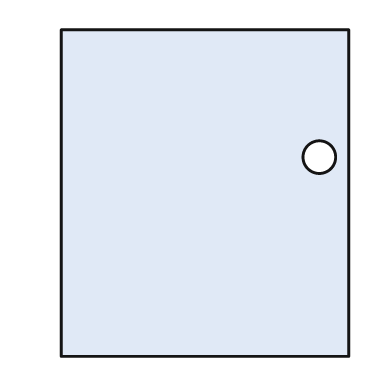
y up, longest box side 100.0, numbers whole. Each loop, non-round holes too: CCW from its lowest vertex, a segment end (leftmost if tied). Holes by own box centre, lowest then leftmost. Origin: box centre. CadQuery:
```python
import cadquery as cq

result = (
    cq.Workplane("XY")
    .moveTo(-44.0, -50.0)
    .lineTo(44.0, -50.0)
    .lineTo(44.0, 50.0)
    .lineTo(-44.0, 50.0)
    .close()
    .moveTo(35.0, 11.0)
    .circle(5.0)
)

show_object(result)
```